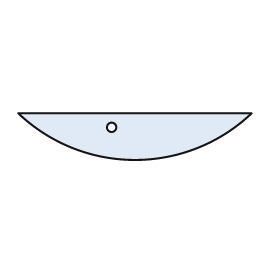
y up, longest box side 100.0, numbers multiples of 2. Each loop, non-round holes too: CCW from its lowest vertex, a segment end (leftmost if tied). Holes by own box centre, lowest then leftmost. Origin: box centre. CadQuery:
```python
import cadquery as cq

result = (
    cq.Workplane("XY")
    .moveTo(-50.0, 10.0)
    .threePointArc((0.0, -10.0), (50.0, 10.0))
    .close()
    .moveTo(-10.0, 4.0)
    .circle(2.0)
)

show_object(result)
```